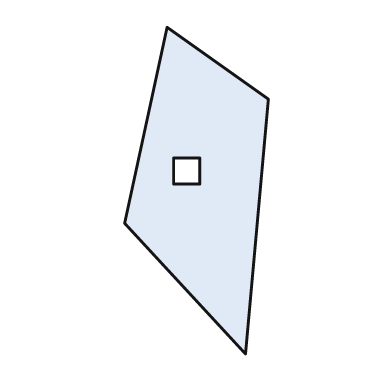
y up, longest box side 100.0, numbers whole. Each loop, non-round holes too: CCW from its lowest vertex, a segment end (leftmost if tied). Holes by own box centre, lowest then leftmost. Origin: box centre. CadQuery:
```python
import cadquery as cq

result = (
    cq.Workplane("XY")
    .moveTo(15.0, -50.0)
    .lineTo(22.0, 28.0)
    .lineTo(-9.0, 50.0)
    .lineTo(-22.0, -10.0)
    .close()
    .moveTo(-7.0, 2.0)
    .lineTo(1.0, 2.0)
    .lineTo(1.0, 10.0)
    .lineTo(-7.0, 10.0)
    .close()
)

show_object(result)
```